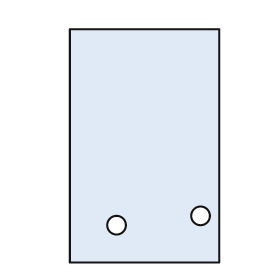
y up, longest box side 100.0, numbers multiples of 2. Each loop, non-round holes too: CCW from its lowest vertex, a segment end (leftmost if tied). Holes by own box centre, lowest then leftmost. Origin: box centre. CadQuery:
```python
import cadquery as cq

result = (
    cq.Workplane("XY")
    .moveTo(-32.0, -50.0)
    .lineTo(32.0, -50.0)
    .lineTo(32.0, 50.0)
    .lineTo(-32.0, 50.0)
    .close()
    .moveTo(-12.0, -34.0)
    .circle(4.0)
    .moveTo(24.0, -30.0)
    .circle(4.0)
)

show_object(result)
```